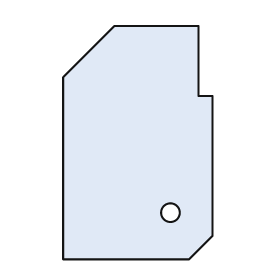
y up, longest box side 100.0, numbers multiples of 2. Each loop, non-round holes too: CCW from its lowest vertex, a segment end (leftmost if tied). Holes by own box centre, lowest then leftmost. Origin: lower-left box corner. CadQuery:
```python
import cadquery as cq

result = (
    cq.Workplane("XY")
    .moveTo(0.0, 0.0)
    .lineTo(54.0, 0.0)
    .lineTo(64.0, 10.0)
    .lineTo(64.0, 70.0)
    .lineTo(58.0, 70.0)
    .lineTo(58.0, 100.0)
    .lineTo(22.0, 100.0)
    .lineTo(0.0, 78.0)
    .close()
    .moveTo(46.0, 20.0)
    .circle(4.0)
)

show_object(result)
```